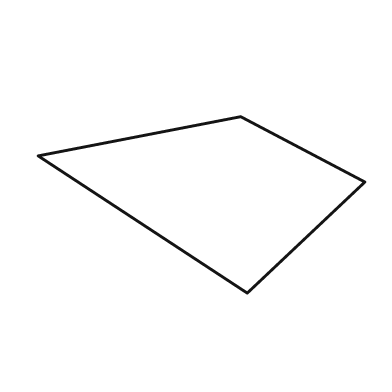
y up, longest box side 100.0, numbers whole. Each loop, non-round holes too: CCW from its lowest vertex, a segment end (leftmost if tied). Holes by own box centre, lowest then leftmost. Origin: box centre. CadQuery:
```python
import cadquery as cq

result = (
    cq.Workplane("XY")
    .moveTo(14.0, -27.0)
    .lineTo(50.0, 7.0)
    .lineTo(12.0, 27.0)
    .lineTo(-50.0, 15.0)
    .close()
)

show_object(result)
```